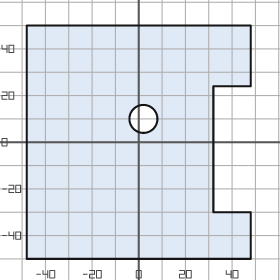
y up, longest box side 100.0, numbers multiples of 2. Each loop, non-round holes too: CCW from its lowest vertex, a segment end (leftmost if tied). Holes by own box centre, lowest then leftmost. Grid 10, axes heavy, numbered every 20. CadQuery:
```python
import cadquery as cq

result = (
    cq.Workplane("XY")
    .moveTo(-48.0, -50.0)
    .lineTo(48.0, -50.0)
    .lineTo(48.0, -30.0)
    .lineTo(32.0, -30.0)
    .lineTo(32.0, 24.0)
    .lineTo(48.0, 24.0)
    .lineTo(48.0, 50.0)
    .lineTo(-48.0, 50.0)
    .close()
    .moveTo(2.0, 10.0)
    .circle(6.0)
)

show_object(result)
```